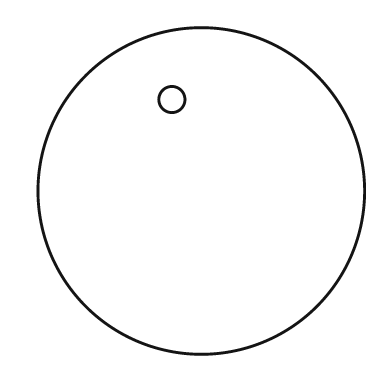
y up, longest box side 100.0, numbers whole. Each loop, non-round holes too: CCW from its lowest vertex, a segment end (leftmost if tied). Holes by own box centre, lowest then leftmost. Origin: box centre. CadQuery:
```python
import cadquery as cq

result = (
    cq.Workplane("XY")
    .moveTo(0.0, 0.0)
    .circle(50.0)
    .moveTo(-9.0, 28.0)
    .circle(4.0)
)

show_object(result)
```